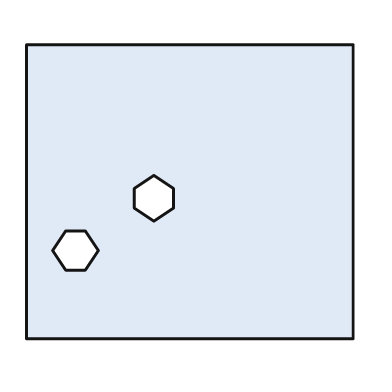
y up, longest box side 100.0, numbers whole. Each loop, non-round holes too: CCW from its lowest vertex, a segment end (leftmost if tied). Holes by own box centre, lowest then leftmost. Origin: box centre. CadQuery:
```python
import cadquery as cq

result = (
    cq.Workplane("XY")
    .moveTo(-50.0, -45.0)
    .lineTo(50.0, -45.0)
    .lineTo(50.0, 45.0)
    .lineTo(-50.0, 45.0)
    .close()
    .moveTo(-38.0, -24.0)
    .lineTo(-32.0, -24.0)
    .lineTo(-28.0, -18.0)
    .lineTo(-32.0, -12.0)
    .lineTo(-38.0, -12.0)
    .lineTo(-42.0, -18.0)
    .close()
    .moveTo(-11.0, -9.0)
    .lineTo(-5.0, -5.0)
    .lineTo(-5.0, 1.0)
    .lineTo(-11.0, 5.0)
    .lineTo(-17.0, 1.0)
    .lineTo(-17.0, -5.0)
    .close()
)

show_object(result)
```